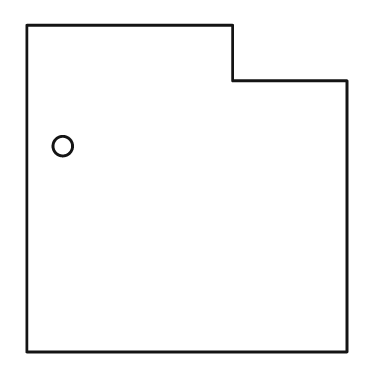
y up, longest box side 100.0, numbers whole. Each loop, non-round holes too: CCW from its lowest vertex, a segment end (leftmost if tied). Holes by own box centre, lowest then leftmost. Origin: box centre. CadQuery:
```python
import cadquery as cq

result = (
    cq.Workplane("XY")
    .moveTo(-49.0, -50.0)
    .lineTo(49.0, -50.0)
    .lineTo(49.0, 33.0)
    .lineTo(14.0, 33.0)
    .lineTo(14.0, 50.0)
    .lineTo(-49.0, 50.0)
    .close()
    .moveTo(-38.0, 13.0)
    .circle(3.0)
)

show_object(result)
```